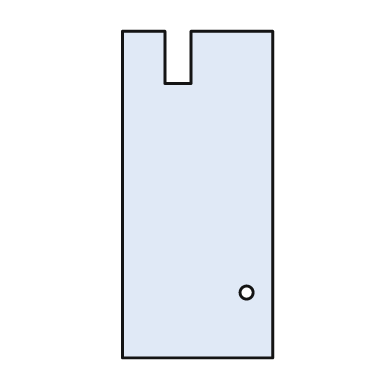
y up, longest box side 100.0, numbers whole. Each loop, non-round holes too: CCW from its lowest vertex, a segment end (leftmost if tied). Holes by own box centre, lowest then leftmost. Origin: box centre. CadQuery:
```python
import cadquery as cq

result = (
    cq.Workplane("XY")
    .moveTo(-23.0, -50.0)
    .lineTo(23.0, -50.0)
    .lineTo(23.0, 50.0)
    .lineTo(-2.0, 50.0)
    .lineTo(-2.0, 34.0)
    .lineTo(-10.0, 34.0)
    .lineTo(-10.0, 50.0)
    .lineTo(-23.0, 50.0)
    .close()
    .moveTo(15.0, -30.0)
    .circle(2.0)
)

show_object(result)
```